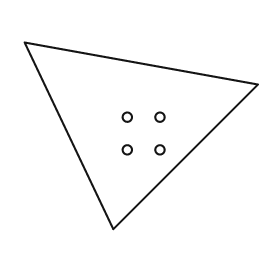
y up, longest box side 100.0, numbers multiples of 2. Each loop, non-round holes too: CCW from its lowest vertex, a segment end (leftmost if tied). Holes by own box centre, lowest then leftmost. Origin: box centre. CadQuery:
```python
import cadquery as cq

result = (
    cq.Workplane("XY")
    .moveTo(-12.0, -40.0)
    .lineTo(50.0, 22.0)
    .lineTo(-50.0, 40.0)
    .close()
    .moveTo(-6.0, -6.0)
    .circle(2.0)
    .moveTo(8.0, -6.0)
    .circle(2.0)
    .moveTo(-6.0, 8.0)
    .circle(2.0)
    .moveTo(8.0, 8.0)
    .circle(2.0)
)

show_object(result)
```